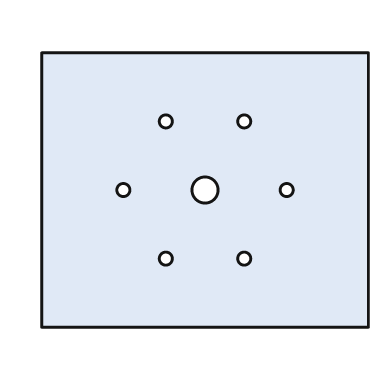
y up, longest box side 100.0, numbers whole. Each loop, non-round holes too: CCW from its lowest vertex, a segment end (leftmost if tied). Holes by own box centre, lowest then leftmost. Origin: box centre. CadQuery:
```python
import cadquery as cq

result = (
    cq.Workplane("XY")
    .moveTo(-50.0, -42.0)
    .lineTo(50.0, -42.0)
    .lineTo(50.0, 42.0)
    .lineTo(-50.0, 42.0)
    .close()
    .moveTo(-12.0, -21.0)
    .circle(2.0)
    .moveTo(12.0, -21.0)
    .circle(2.0)
    .moveTo(-25.0, 0.0)
    .circle(2.0)
    .moveTo(0.0, 0.0)
    .circle(4.0)
    .moveTo(25.0, 0.0)
    .circle(2.0)
    .moveTo(-12.0, 21.0)
    .circle(2.0)
    .moveTo(12.0, 21.0)
    .circle(2.0)
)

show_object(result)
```